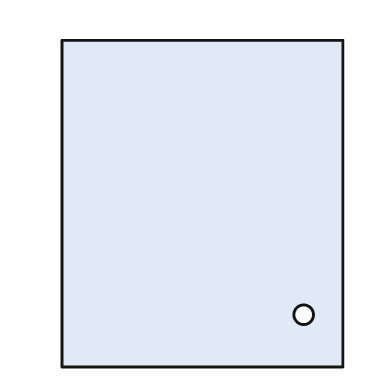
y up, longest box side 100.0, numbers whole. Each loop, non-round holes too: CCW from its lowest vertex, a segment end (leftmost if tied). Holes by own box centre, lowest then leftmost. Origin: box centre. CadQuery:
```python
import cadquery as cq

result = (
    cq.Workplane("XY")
    .moveTo(-43.0, -50.0)
    .lineTo(43.0, -50.0)
    .lineTo(43.0, 50.0)
    .lineTo(-43.0, 50.0)
    .close()
    .moveTo(31.0, -34.0)
    .circle(3.0)
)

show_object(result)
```